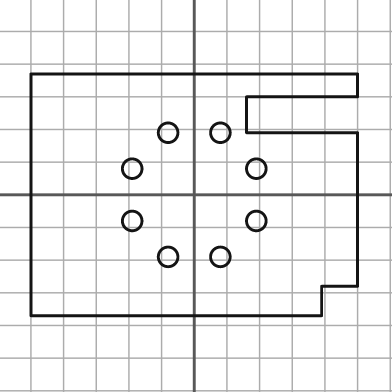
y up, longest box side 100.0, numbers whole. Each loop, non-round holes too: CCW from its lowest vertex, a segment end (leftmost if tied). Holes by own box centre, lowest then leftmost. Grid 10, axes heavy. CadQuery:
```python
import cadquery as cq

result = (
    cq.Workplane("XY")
    .moveTo(-50.0, -37.0)
    .lineTo(39.0, -37.0)
    .lineTo(39.0, -28.0)
    .lineTo(50.0, -28.0)
    .lineTo(50.0, 19.0)
    .lineTo(16.0, 19.0)
    .lineTo(16.0, 30.0)
    .lineTo(50.0, 30.0)
    .lineTo(50.0, 37.0)
    .lineTo(-50.0, 37.0)
    .close()
    .moveTo(-8.0, -19.0)
    .circle(3.0)
    .moveTo(8.0, -19.0)
    .circle(3.0)
    .moveTo(-19.0, -8.0)
    .circle(3.0)
    .moveTo(19.0, -8.0)
    .circle(3.0)
    .moveTo(-19.0, 8.0)
    .circle(3.0)
    .moveTo(19.0, 8.0)
    .circle(3.0)
    .moveTo(-8.0, 19.0)
    .circle(3.0)
    .moveTo(8.0, 19.0)
    .circle(3.0)
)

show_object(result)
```